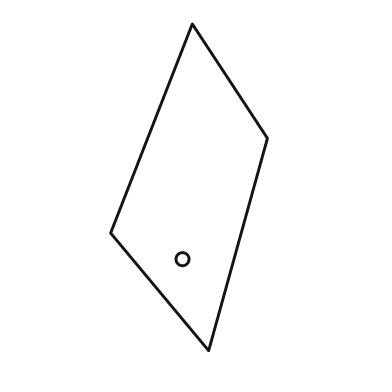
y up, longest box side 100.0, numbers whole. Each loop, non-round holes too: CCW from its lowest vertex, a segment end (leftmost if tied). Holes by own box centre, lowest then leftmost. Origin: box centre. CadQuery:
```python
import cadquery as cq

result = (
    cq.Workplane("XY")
    .moveTo(6.0, -50.0)
    .lineTo(24.0, 15.0)
    .lineTo(1.0, 50.0)
    .lineTo(-24.0, -14.0)
    .close()
    .moveTo(-2.0, -22.0)
    .circle(2.0)
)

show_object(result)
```